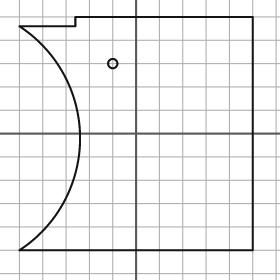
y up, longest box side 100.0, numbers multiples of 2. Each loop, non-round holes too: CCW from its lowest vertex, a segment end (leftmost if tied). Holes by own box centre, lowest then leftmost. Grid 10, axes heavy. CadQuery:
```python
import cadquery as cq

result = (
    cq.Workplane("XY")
    .moveTo(-50.0, -50.0)
    .lineTo(50.0, -50.0)
    .lineTo(50.0, 50.0)
    .lineTo(-26.0, 50.0)
    .lineTo(-26.0, 46.0)
    .lineTo(-50.0, 46.0)
    .threePointArc((-24.0, -2.0), (-50.0, -50.0))
    .close()
    .moveTo(-10.0, 30.0)
    .circle(2.0)
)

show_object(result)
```